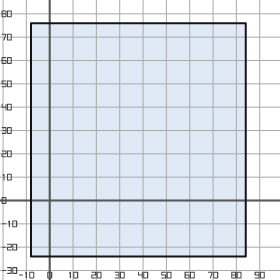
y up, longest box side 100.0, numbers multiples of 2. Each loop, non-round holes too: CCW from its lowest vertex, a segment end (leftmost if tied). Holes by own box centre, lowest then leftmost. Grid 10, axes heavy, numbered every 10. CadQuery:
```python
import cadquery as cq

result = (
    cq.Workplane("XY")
    .moveTo(-8.0, -24.0)
    .lineTo(84.0, -24.0)
    .lineTo(84.0, 76.0)
    .lineTo(-8.0, 76.0)
    .close()
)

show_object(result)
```